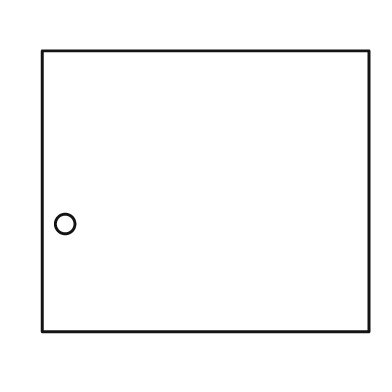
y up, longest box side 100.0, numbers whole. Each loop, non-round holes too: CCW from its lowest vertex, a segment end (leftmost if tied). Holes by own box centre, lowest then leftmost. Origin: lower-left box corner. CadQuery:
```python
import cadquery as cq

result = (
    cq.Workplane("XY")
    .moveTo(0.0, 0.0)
    .lineTo(100.0, 0.0)
    .lineTo(100.0, 86.0)
    .lineTo(0.0, 86.0)
    .close()
    .moveTo(7.0, 33.0)
    .circle(3.0)
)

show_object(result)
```